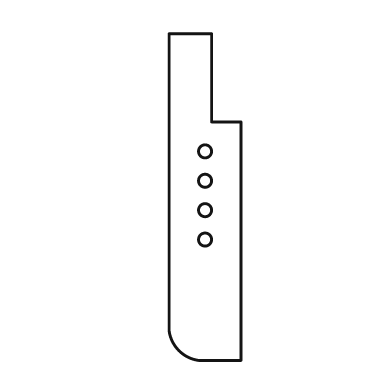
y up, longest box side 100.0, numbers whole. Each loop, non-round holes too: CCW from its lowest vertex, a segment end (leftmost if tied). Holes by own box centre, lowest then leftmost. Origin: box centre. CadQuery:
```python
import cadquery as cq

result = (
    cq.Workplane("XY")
    .moveTo(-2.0, -50.0)
    .lineTo(11.0, -50.0)
    .lineTo(11.0, 23.0)
    .lineTo(2.0, 23.0)
    .lineTo(2.0, 50.0)
    .lineTo(-11.0, 50.0)
    .lineTo(-11.0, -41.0)
    .threePointArc((-8.0, -47.0), (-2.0, -50.0))
    .close()
    .moveTo(0.0, -13.0)
    .circle(2.0)
    .moveTo(0.0, -4.0)
    .circle(2.0)
    .moveTo(0.0, 5.0)
    .circle(2.0)
    .moveTo(0.0, 14.0)
    .circle(2.0)
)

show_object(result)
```